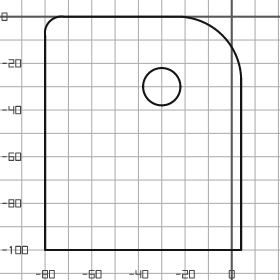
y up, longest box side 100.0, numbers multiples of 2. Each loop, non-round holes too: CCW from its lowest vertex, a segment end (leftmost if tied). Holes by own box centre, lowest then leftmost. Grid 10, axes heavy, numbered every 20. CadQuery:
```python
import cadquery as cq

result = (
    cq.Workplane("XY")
    .moveTo(-80.0, -100.0)
    .lineTo(4.0, -100.0)
    .lineTo(4.0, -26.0)
    .threePointArc((-4.0, -8.0), (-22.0, 0.0))
    .lineTo(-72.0, 0.0)
    .threePointArc((-78.0, -2.0), (-80.0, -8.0))
    .close()
    .moveTo(-30.0, -30.0)
    .circle(8.0)
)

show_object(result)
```